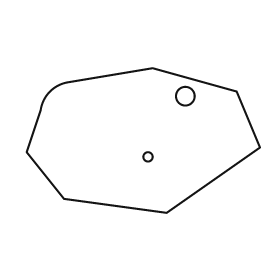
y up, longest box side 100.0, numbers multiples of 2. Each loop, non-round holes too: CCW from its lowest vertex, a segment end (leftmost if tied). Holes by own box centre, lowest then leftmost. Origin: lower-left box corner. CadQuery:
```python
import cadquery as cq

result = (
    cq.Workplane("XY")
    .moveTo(60.0, 0.0)
    .lineTo(100.0, 28.0)
    .lineTo(90.0, 52.0)
    .lineTo(54.0, 62.0)
    .lineTo(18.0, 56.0)
    .threePointArc((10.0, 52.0), (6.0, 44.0))
    .lineTo(0.0, 26.0)
    .lineTo(16.0, 6.0)
    .close()
    .moveTo(52.0, 24.0)
    .circle(2.0)
    .moveTo(68.0, 50.0)
    .circle(4.0)
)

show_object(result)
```